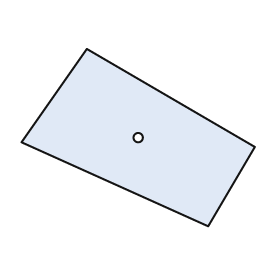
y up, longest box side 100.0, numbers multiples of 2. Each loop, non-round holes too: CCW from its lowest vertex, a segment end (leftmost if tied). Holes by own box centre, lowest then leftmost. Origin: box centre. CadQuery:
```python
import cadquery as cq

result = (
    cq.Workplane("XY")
    .moveTo(30.0, -38.0)
    .lineTo(50.0, -4.0)
    .lineTo(-22.0, 38.0)
    .lineTo(-50.0, -2.0)
    .close()
    .moveTo(0.0, 0.0)
    .circle(2.0)
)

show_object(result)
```